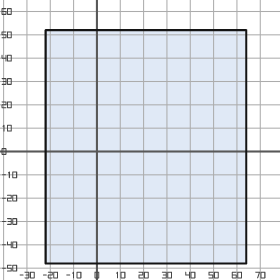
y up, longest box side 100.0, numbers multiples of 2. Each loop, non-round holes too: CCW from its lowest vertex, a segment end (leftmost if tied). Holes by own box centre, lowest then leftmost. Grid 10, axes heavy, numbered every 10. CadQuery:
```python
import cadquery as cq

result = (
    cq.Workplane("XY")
    .moveTo(-22.0, -48.0)
    .lineTo(64.0, -48.0)
    .lineTo(64.0, 52.0)
    .lineTo(-22.0, 52.0)
    .close()
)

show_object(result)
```